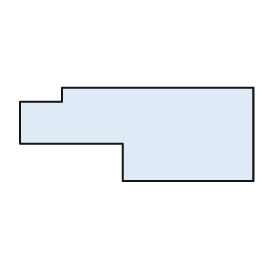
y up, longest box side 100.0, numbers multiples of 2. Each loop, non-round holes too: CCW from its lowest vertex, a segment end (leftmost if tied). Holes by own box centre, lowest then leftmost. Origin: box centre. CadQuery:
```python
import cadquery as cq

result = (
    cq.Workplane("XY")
    .moveTo(-6.0, -20.0)
    .lineTo(50.0, -20.0)
    .lineTo(50.0, 20.0)
    .lineTo(-32.0, 20.0)
    .lineTo(-32.0, 14.0)
    .lineTo(-50.0, 14.0)
    .lineTo(-50.0, -4.0)
    .lineTo(-6.0, -4.0)
    .close()
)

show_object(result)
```